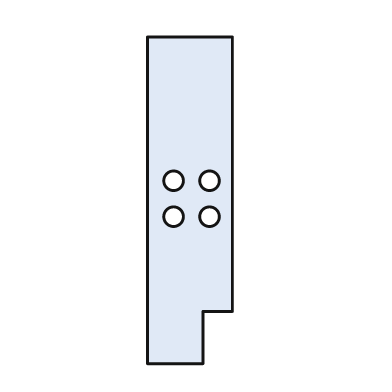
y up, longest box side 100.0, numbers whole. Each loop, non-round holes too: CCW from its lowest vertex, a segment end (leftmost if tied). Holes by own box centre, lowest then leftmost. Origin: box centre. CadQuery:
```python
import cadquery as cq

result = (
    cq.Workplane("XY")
    .moveTo(-13.0, -50.0)
    .lineTo(4.0, -50.0)
    .lineTo(4.0, -34.0)
    .lineTo(13.0, -34.0)
    .lineTo(13.0, 50.0)
    .lineTo(-13.0, 50.0)
    .close()
    .moveTo(-5.0, -5.0)
    .circle(3.0)
    .moveTo(6.0, -5.0)
    .circle(3.0)
    .moveTo(-5.0, 6.0)
    .circle(3.0)
    .moveTo(6.0, 6.0)
    .circle(3.0)
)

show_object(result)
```